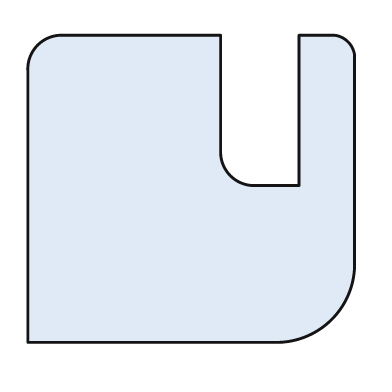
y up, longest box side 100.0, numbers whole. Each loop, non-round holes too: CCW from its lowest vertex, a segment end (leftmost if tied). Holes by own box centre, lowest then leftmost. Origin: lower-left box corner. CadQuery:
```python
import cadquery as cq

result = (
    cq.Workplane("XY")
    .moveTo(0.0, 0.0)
    .lineTo(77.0, 0.0)
    .threePointArc((93.0, 7.0), (100.0, 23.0))
    .lineTo(100.0, 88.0)
    .threePointArc((98.0, 92.0), (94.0, 94.0))
    .lineTo(83.0, 94.0)
    .lineTo(83.0, 48.0)
    .lineTo(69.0, 48.0)
    .threePointArc((62.0, 51.0), (59.0, 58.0))
    .lineTo(59.0, 94.0)
    .lineTo(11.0, 94.0)
    .threePointArc((3.0, 91.0), (0.0, 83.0))
    .close()
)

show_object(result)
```